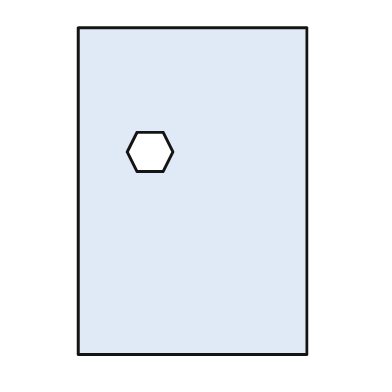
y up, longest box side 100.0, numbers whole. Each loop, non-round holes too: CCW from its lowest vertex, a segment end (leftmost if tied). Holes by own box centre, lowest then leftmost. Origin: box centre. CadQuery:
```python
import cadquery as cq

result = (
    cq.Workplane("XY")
    .moveTo(-35.0, -50.0)
    .lineTo(35.0, -50.0)
    .lineTo(35.0, 50.0)
    .lineTo(-35.0, 50.0)
    .close()
    .moveTo(-17.0, 6.0)
    .lineTo(-9.0, 6.0)
    .lineTo(-6.0, 12.0)
    .lineTo(-9.0, 18.0)
    .lineTo(-17.0, 18.0)
    .lineTo(-20.0, 12.0)
    .close()
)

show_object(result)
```